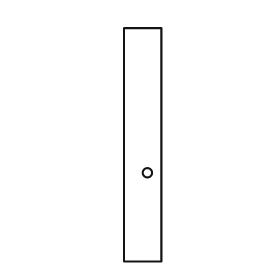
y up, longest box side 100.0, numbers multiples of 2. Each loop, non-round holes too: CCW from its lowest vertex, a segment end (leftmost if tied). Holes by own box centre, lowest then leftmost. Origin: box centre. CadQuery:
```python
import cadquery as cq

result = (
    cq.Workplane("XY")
    .moveTo(-8.0, -50.0)
    .lineTo(8.0, -50.0)
    .lineTo(8.0, 50.0)
    .lineTo(-8.0, 50.0)
    .close()
    .moveTo(2.0, -12.0)
    .circle(2.0)
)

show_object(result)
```